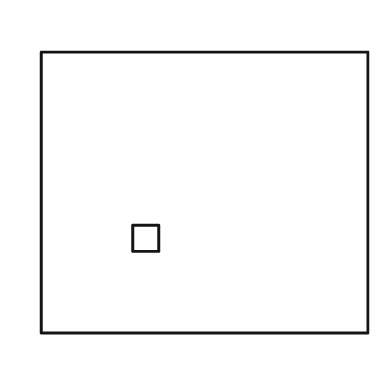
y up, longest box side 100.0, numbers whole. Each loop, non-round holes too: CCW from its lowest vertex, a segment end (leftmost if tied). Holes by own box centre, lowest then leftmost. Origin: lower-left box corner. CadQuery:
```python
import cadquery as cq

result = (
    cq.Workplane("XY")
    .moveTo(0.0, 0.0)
    .lineTo(100.0, 0.0)
    .lineTo(100.0, 86.0)
    .lineTo(0.0, 86.0)
    .close()
    .moveTo(28.0, 25.0)
    .lineTo(36.0, 25.0)
    .lineTo(36.0, 33.0)
    .lineTo(28.0, 33.0)
    .close()
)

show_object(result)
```